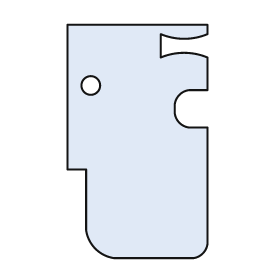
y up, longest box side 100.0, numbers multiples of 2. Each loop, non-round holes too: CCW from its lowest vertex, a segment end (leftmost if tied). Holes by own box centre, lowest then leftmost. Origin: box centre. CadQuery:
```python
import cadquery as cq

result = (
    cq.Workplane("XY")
    .moveTo(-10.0, -50.0)
    .lineTo(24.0, -50.0)
    .threePointArc((28.0, -48.0), (30.0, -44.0))
    .lineTo(30.0, 6.0)
    .lineTo(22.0, 6.0)
    .threePointArc((18.0, 8.0), (16.0, 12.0))
    .lineTo(16.0, 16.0)
    .threePointArc((18.0, 20.0), (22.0, 22.0))
    .lineTo(30.0, 22.0)
    .lineTo(30.0, 36.0)
    .threePointArc((20.0, 38.0), (10.0, 36.0))
    .lineTo(10.0, 46.0)
    .threePointArc((20.0, 44.0), (30.0, 46.0))
    .lineTo(30.0, 50.0)
    .lineTo(-30.0, 50.0)
    .lineTo(-30.0, -12.0)
    .lineTo(-22.0, -12.0)
    .lineTo(-22.0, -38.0)
    .threePointArc((-18.0, -46.0), (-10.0, -50.0))
    .close()
    .moveTo(-20.0, 24.0)
    .circle(4.0)
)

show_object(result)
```